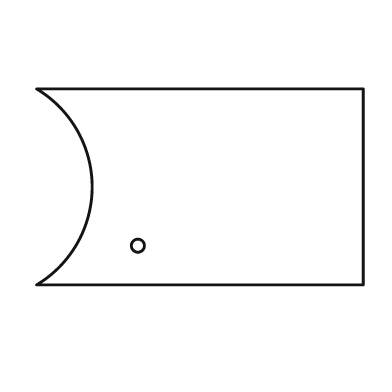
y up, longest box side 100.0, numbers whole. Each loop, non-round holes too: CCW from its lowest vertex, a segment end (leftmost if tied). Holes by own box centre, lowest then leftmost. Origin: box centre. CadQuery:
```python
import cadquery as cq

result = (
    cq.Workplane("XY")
    .moveTo(-50.0, -30.0)
    .lineTo(50.0, -30.0)
    .lineTo(50.0, 30.0)
    .lineTo(-50.0, 30.0)
    .threePointArc((-33.0, 0.0), (-50.0, -30.0))
    .close()
    .moveTo(-19.0, -18.0)
    .circle(2.0)
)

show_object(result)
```